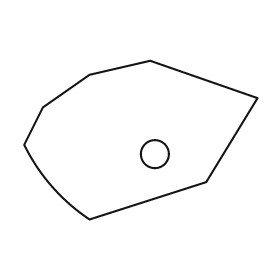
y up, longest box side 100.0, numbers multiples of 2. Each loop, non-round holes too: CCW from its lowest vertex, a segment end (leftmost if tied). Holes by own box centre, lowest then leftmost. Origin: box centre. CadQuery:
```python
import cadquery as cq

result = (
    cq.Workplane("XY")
    .moveTo(-22.0, -34.0)
    .lineTo(28.0, -18.0)
    .lineTo(50.0, 18.0)
    .lineTo(4.0, 34.0)
    .lineTo(-22.0, 28.0)
    .lineTo(-42.0, 14.0)
    .lineTo(-50.0, -2.0)
    .threePointArc((-38.0, -20.0), (-22.0, -34.0))
    .close()
    .moveTo(6.0, -6.0)
    .circle(6.0)
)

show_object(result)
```